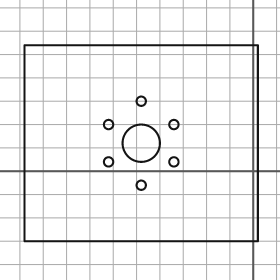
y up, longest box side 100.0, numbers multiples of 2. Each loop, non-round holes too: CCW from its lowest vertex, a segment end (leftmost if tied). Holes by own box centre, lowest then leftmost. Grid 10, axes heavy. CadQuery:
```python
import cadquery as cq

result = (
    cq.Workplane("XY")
    .moveTo(-98.0, -30.0)
    .lineTo(2.0, -30.0)
    .lineTo(2.0, 54.0)
    .lineTo(-98.0, 54.0)
    .close()
    .moveTo(-48.0, -6.0)
    .circle(2.0)
    .moveTo(-62.0, 4.0)
    .circle(2.0)
    .moveTo(-34.0, 4.0)
    .circle(2.0)
    .moveTo(-48.0, 12.0)
    .circle(8.0)
    .moveTo(-62.0, 20.0)
    .circle(2.0)
    .moveTo(-34.0, 20.0)
    .circle(2.0)
    .moveTo(-48.0, 30.0)
    .circle(2.0)
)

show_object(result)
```